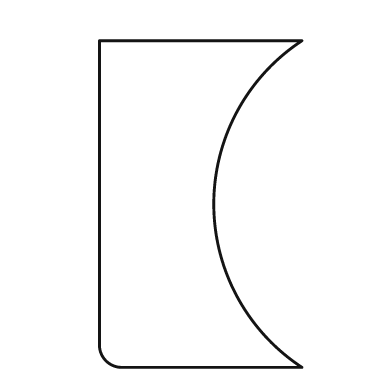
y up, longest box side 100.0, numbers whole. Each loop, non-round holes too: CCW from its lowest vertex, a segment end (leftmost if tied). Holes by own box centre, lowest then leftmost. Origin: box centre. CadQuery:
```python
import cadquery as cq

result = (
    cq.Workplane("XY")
    .moveTo(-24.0, -50.0)
    .lineTo(31.0, -50.0)
    .threePointArc((4.0, 0.0), (31.0, 50.0))
    .lineTo(-31.0, 50.0)
    .lineTo(-31.0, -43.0)
    .threePointArc((-29.0, -48.0), (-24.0, -50.0))
    .close()
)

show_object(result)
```